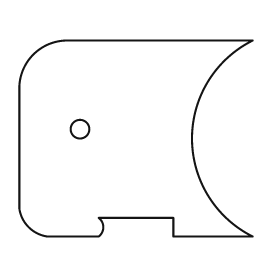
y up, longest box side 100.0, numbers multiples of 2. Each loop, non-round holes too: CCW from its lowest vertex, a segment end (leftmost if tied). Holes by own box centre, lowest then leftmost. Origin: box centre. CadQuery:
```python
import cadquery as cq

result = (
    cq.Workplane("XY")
    .moveTo(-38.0, -42.0)
    .lineTo(-16.0, -42.0)
    .threePointArc((-14.0, -38.0), (-16.0, -34.0))
    .lineTo(16.0, -34.0)
    .lineTo(16.0, -42.0)
    .lineTo(50.0, -42.0)
    .threePointArc((24.0, 0.0), (50.0, 42.0))
    .lineTo(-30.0, 42.0)
    .threePointArc((-44.0, 36.0), (-50.0, 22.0))
    .lineTo(-50.0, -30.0)
    .threePointArc((-46.0, -38.0), (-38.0, -42.0))
    .close()
    .moveTo(-24.0, 4.0)
    .circle(4.0)
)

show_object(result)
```